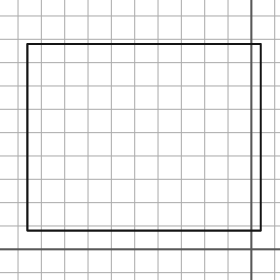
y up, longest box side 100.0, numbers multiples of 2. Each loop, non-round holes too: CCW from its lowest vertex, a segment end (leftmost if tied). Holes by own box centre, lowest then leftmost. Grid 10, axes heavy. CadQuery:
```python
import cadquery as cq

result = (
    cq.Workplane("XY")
    .moveTo(-96.0, 8.0)
    .lineTo(4.0, 8.0)
    .lineTo(4.0, 88.0)
    .lineTo(-96.0, 88.0)
    .close()
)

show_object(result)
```